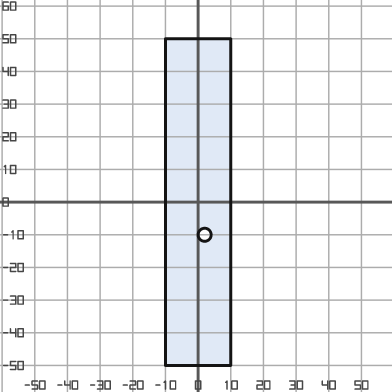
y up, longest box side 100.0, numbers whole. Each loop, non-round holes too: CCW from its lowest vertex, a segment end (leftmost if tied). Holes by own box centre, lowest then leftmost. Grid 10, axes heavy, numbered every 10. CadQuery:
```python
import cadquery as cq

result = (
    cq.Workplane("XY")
    .moveTo(-10.0, -50.0)
    .lineTo(10.0, -50.0)
    .lineTo(10.0, 50.0)
    .lineTo(-10.0, 50.0)
    .close()
    .moveTo(2.0, -10.0)
    .circle(2.0)
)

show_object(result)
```